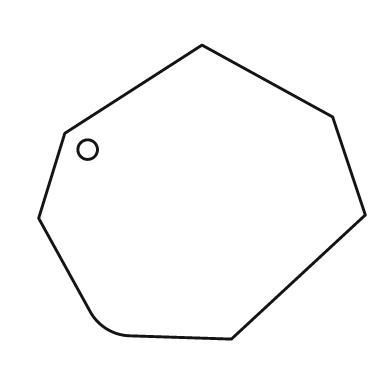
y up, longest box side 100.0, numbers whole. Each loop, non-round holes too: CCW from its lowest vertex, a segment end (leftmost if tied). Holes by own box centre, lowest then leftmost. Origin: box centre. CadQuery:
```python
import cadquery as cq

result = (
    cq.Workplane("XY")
    .moveTo(9.0, -45.0)
    .lineTo(50.0, -7.0)
    .lineTo(40.0, 23.0)
    .lineTo(0.0, 45.0)
    .lineTo(-42.0, 18.0)
    .lineTo(-50.0, -8.0)
    .lineTo(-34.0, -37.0)
    .threePointArc((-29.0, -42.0), (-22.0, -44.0))
    .close()
    .moveTo(-35.0, 13.0)
    .circle(3.0)
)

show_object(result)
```